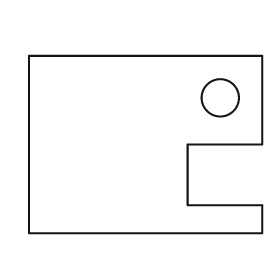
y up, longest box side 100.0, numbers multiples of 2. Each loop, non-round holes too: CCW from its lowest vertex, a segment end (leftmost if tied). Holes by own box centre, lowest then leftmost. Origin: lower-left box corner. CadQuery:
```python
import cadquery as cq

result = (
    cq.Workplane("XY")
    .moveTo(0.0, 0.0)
    .lineTo(100.0, 0.0)
    .lineTo(100.0, 12.0)
    .lineTo(68.0, 12.0)
    .lineTo(68.0, 38.0)
    .lineTo(100.0, 38.0)
    .lineTo(100.0, 76.0)
    .lineTo(0.0, 76.0)
    .close()
    .moveTo(82.0, 58.0)
    .circle(8.0)
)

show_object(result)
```